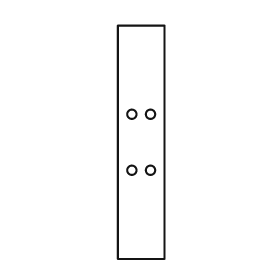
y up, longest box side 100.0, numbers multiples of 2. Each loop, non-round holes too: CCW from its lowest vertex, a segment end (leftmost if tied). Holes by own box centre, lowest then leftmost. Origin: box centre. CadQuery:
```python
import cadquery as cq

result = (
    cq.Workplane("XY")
    .moveTo(-10.0, -50.0)
    .lineTo(10.0, -50.0)
    .lineTo(10.0, 50.0)
    .lineTo(-10.0, 50.0)
    .close()
    .moveTo(-4.0, -12.0)
    .circle(2.0)
    .moveTo(4.0, -12.0)
    .circle(2.0)
    .moveTo(-4.0, 12.0)
    .circle(2.0)
    .moveTo(4.0, 12.0)
    .circle(2.0)
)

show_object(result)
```